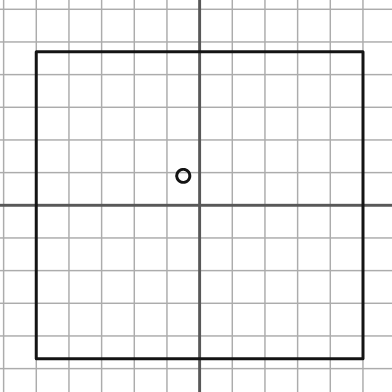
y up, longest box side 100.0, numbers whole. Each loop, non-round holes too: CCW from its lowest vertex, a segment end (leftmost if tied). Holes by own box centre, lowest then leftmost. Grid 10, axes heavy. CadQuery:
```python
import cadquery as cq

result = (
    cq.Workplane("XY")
    .moveTo(-50.0, -47.0)
    .lineTo(50.0, -47.0)
    .lineTo(50.0, 47.0)
    .lineTo(-50.0, 47.0)
    .close()
    .moveTo(-5.0, 9.0)
    .circle(2.0)
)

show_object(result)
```